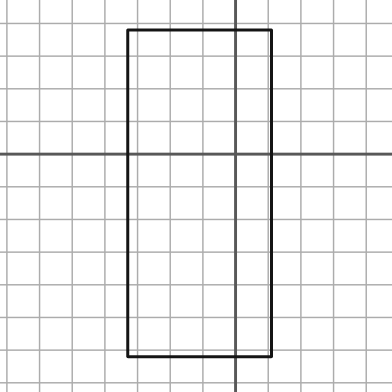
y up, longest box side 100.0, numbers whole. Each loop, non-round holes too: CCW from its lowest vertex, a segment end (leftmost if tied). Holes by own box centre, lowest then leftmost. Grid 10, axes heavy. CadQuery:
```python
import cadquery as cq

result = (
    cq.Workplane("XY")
    .moveTo(-33.0, -62.0)
    .lineTo(11.0, -62.0)
    .lineTo(11.0, 38.0)
    .lineTo(-33.0, 38.0)
    .close()
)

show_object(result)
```